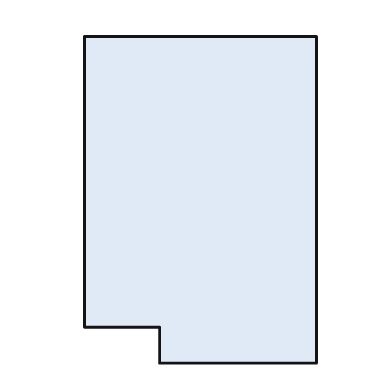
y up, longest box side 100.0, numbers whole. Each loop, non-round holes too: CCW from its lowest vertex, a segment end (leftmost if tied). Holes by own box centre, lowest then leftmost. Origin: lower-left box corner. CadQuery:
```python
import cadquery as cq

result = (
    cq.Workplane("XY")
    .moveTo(23.0, 0.0)
    .lineTo(71.0, 0.0)
    .lineTo(71.0, 100.0)
    .lineTo(0.0, 100.0)
    .lineTo(0.0, 11.0)
    .lineTo(23.0, 11.0)
    .close()
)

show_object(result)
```